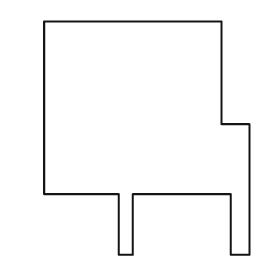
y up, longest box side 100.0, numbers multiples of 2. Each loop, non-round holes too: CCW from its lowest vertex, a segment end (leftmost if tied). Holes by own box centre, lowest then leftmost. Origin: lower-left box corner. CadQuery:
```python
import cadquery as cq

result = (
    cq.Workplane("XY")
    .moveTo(32.0, 0.0)
    .lineTo(38.0, 0.0)
    .lineTo(38.0, 26.0)
    .lineTo(80.0, 26.0)
    .lineTo(80.0, 0.0)
    .lineTo(88.0, 0.0)
    .lineTo(88.0, 56.0)
    .lineTo(76.0, 56.0)
    .lineTo(76.0, 100.0)
    .lineTo(0.0, 100.0)
    .lineTo(0.0, 26.0)
    .lineTo(32.0, 26.0)
    .close()
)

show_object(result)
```